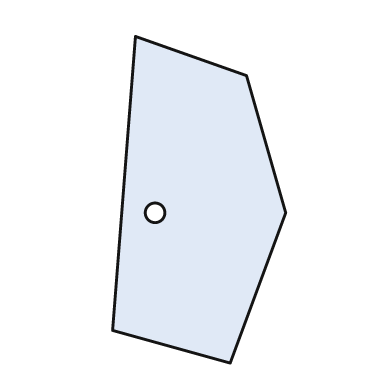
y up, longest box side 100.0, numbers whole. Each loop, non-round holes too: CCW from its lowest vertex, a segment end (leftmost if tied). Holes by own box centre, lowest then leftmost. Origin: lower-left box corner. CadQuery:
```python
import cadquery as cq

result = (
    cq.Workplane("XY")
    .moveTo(36.0, 0.0)
    .lineTo(53.0, 46.0)
    .lineTo(41.0, 88.0)
    .lineTo(7.0, 100.0)
    .lineTo(0.0, 10.0)
    .close()
    .moveTo(13.0, 46.0)
    .circle(3.0)
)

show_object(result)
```